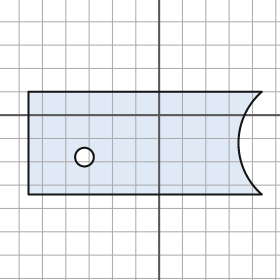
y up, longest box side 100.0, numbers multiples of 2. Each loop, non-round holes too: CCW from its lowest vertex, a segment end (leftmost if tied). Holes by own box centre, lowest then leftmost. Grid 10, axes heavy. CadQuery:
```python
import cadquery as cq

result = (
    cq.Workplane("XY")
    .moveTo(-56.0, -34.0)
    .lineTo(44.0, -34.0)
    .threePointArc((34.0, -12.0), (44.0, 10.0))
    .lineTo(-56.0, 10.0)
    .close()
    .moveTo(-32.0, -18.0)
    .circle(4.0)
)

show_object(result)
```